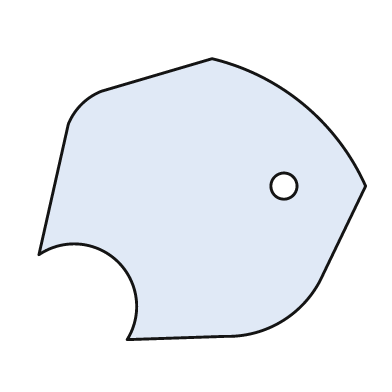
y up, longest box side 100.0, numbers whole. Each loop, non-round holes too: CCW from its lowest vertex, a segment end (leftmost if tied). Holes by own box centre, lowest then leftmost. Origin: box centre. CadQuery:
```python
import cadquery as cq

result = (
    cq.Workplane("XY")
    .moveTo(-23.0, -43.0)
    .lineTo(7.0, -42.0)
    .threePointArc((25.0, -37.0), (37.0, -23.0))
    .lineTo(50.0, 4.0)
    .threePointArc((31.0, 29.0), (3.0, 43.0))
    .lineTo(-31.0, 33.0)
    .threePointArc((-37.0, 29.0), (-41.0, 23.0))
    .lineTo(-50.0, -17.0)
    .threePointArc((-26.0, -19.0), (-23.0, -43.0))
    .close()
    .moveTo(25.0, 4.0)
    .circle(4.0)
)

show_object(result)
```